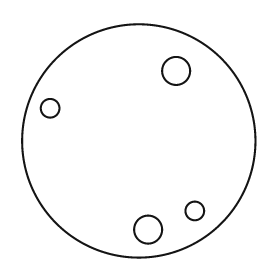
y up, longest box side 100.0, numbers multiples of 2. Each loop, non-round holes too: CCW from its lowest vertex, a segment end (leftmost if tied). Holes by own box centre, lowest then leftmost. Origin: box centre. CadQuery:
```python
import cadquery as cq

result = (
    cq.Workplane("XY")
    .moveTo(0.0, 0.0)
    .circle(50.0)
    .moveTo(4.0, -38.0)
    .circle(6.0)
    .moveTo(24.0, -30.0)
    .circle(4.0)
    .moveTo(-38.0, 14.0)
    .circle(4.0)
    .moveTo(16.0, 30.0)
    .circle(6.0)
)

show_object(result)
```